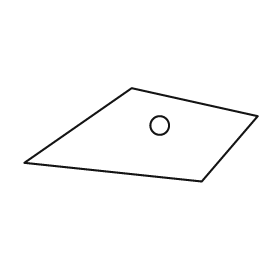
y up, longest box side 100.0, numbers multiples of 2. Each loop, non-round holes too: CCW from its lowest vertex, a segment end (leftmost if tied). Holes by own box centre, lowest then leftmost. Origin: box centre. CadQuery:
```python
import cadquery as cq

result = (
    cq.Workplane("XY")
    .moveTo(26.0, -20.0)
    .lineTo(50.0, 8.0)
    .lineTo(-4.0, 20.0)
    .lineTo(-50.0, -12.0)
    .close()
    .moveTo(8.0, 4.0)
    .circle(4.0)
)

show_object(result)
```